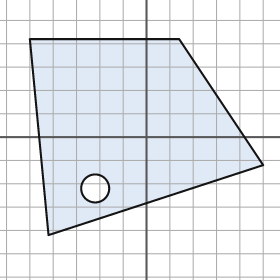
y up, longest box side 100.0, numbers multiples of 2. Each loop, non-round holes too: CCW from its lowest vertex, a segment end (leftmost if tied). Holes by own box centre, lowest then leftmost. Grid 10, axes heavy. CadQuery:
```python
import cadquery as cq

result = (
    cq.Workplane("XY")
    .moveTo(-42.0, -42.0)
    .lineTo(50.0, -12.0)
    .lineTo(14.0, 42.0)
    .lineTo(-50.0, 42.0)
    .close()
    .moveTo(-22.0, -22.0)
    .circle(6.0)
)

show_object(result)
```